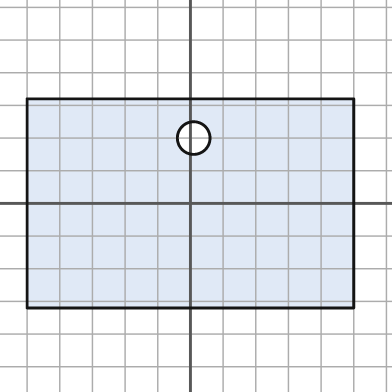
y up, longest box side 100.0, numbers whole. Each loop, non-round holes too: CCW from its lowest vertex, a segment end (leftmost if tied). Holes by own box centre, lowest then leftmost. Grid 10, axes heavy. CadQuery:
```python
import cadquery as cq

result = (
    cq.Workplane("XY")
    .moveTo(-50.0, -32.0)
    .lineTo(50.0, -32.0)
    .lineTo(50.0, 32.0)
    .lineTo(-50.0, 32.0)
    .close()
    .moveTo(1.0, 20.0)
    .circle(5.0)
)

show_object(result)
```